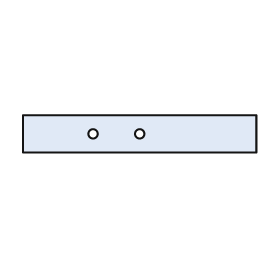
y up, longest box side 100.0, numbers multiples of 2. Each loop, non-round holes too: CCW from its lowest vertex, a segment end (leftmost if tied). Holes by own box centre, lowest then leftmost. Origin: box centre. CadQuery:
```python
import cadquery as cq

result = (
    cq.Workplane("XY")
    .moveTo(-50.0, -8.0)
    .lineTo(50.0, -8.0)
    .lineTo(50.0, 8.0)
    .lineTo(-50.0, 8.0)
    .close()
    .moveTo(-20.0, 0.0)
    .circle(2.0)
    .moveTo(0.0, 0.0)
    .circle(2.0)
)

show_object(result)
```